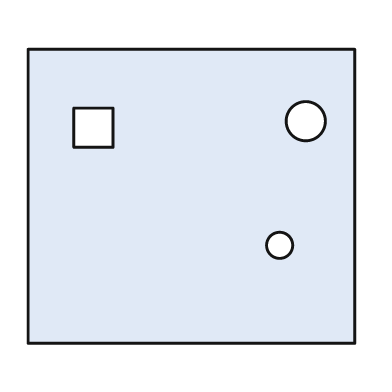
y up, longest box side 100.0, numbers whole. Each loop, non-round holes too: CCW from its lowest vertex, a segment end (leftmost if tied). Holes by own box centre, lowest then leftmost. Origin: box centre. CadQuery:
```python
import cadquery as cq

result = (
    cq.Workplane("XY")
    .moveTo(-50.0, -45.0)
    .lineTo(50.0, -45.0)
    .lineTo(50.0, 45.0)
    .lineTo(-50.0, 45.0)
    .close()
    .moveTo(27.0, -15.0)
    .circle(4.0)
    .moveTo(-36.0, 15.0)
    .lineTo(-24.0, 15.0)
    .lineTo(-24.0, 27.0)
    .lineTo(-36.0, 27.0)
    .close()
    .moveTo(35.0, 23.0)
    .circle(6.0)
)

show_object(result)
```